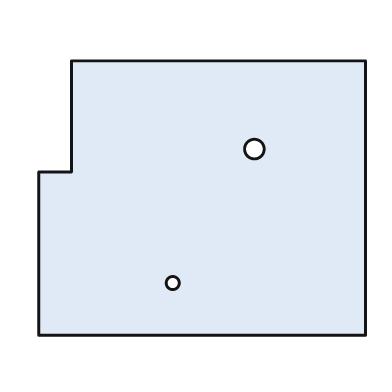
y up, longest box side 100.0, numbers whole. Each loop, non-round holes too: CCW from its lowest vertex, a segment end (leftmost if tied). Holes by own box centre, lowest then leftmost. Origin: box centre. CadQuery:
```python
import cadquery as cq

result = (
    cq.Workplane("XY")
    .moveTo(-50.0, -42.0)
    .lineTo(50.0, -42.0)
    .lineTo(50.0, 42.0)
    .lineTo(-40.0, 42.0)
    .lineTo(-40.0, 8.0)
    .lineTo(-50.0, 8.0)
    .close()
    .moveTo(-9.0, -26.0)
    .circle(2.0)
    .moveTo(16.0, 15.0)
    .circle(3.0)
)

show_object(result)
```